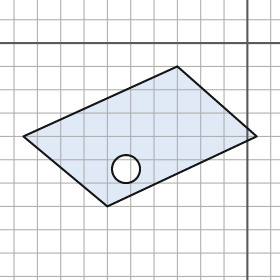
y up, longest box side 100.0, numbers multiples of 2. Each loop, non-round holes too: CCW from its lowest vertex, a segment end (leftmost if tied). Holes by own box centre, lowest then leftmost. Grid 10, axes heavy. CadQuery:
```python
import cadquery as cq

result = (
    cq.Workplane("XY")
    .moveTo(-60.0, -70.0)
    .lineTo(4.0, -40.0)
    .lineTo(-30.0, -10.0)
    .lineTo(-96.0, -40.0)
    .close()
    .moveTo(-52.0, -54.0)
    .circle(6.0)
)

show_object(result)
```